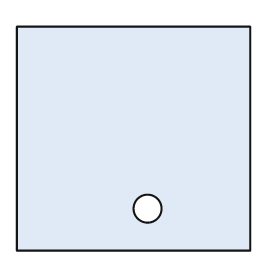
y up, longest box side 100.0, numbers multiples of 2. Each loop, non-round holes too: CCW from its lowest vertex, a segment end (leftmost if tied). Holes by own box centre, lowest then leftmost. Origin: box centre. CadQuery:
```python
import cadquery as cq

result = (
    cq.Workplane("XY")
    .moveTo(-50.0, -48.0)
    .lineTo(50.0, -48.0)
    .lineTo(50.0, 48.0)
    .lineTo(-50.0, 48.0)
    .close()
    .moveTo(6.0, -30.0)
    .circle(6.0)
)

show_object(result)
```